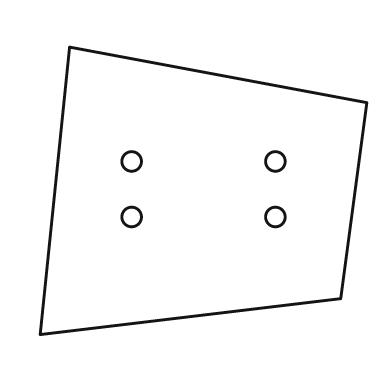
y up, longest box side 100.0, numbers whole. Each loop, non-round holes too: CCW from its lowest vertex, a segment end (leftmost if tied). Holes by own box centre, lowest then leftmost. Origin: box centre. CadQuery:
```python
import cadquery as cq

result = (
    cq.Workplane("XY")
    .moveTo(-50.0, -44.0)
    .lineTo(42.0, -33.0)
    .lineTo(50.0, 27.0)
    .lineTo(-41.0, 44.0)
    .close()
    .moveTo(-22.0, -8.0)
    .circle(3.0)
    .moveTo(22.0, -8.0)
    .circle(3.0)
    .moveTo(-22.0, 9.0)
    .circle(3.0)
    .moveTo(22.0, 9.0)
    .circle(3.0)
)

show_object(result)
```